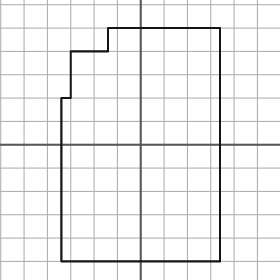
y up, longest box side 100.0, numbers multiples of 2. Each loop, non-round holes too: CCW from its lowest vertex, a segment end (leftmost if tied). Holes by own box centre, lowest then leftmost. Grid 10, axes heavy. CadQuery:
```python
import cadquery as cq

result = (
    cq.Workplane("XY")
    .moveTo(-34.0, -50.0)
    .lineTo(34.0, -50.0)
    .lineTo(34.0, 50.0)
    .lineTo(-14.0, 50.0)
    .lineTo(-14.0, 40.0)
    .lineTo(-30.0, 40.0)
    .lineTo(-30.0, 20.0)
    .lineTo(-34.0, 20.0)
    .close()
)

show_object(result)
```